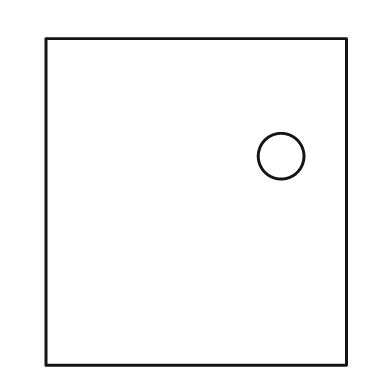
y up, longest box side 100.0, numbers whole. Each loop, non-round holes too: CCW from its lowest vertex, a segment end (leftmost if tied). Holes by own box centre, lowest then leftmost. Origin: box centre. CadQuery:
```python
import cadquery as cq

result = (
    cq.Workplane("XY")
    .moveTo(-46.0, -50.0)
    .lineTo(46.0, -50.0)
    .lineTo(46.0, 50.0)
    .lineTo(-46.0, 50.0)
    .close()
    .moveTo(26.0, 14.0)
    .circle(7.0)
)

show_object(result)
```